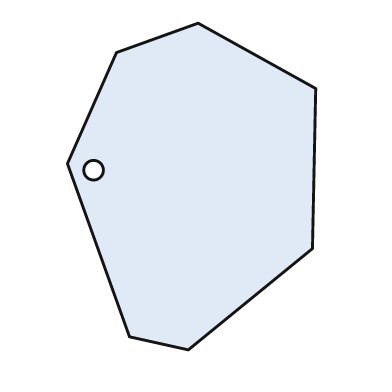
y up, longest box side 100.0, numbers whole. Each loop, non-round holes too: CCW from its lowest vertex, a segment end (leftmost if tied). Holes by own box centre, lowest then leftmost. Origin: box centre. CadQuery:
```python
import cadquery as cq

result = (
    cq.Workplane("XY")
    .moveTo(-1.0, -50.0)
    .lineTo(37.0, -19.0)
    .lineTo(38.0, 30.0)
    .lineTo(2.0, 50.0)
    .lineTo(-23.0, 41.0)
    .lineTo(-38.0, 7.0)
    .lineTo(-19.0, -46.0)
    .close()
    .moveTo(-30.0, 5.0)
    .circle(3.0)
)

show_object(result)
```